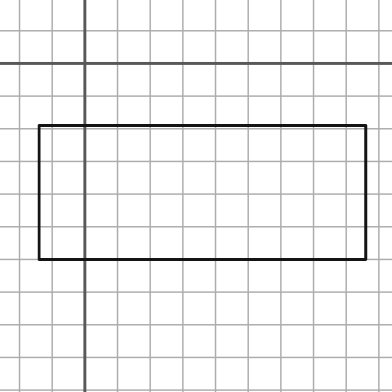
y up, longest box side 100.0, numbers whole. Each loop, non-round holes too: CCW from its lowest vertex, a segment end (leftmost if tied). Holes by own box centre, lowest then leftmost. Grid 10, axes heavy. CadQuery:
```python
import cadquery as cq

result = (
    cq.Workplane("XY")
    .moveTo(-14.0, -60.0)
    .lineTo(86.0, -60.0)
    .lineTo(86.0, -19.0)
    .lineTo(-14.0, -19.0)
    .close()
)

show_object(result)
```